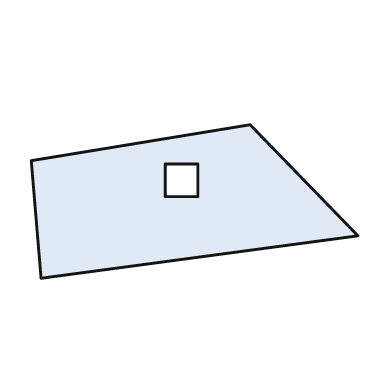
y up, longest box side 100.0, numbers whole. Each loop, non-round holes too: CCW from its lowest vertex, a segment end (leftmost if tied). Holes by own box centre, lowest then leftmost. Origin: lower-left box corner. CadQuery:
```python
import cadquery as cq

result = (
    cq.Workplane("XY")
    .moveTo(3.0, 0.0)
    .lineTo(100.0, 13.0)
    .lineTo(67.0, 47.0)
    .lineTo(0.0, 36.0)
    .close()
    .moveTo(41.0, 25.0)
    .lineTo(51.0, 25.0)
    .lineTo(51.0, 35.0)
    .lineTo(41.0, 35.0)
    .close()
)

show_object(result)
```